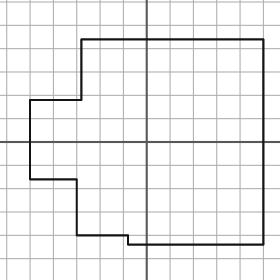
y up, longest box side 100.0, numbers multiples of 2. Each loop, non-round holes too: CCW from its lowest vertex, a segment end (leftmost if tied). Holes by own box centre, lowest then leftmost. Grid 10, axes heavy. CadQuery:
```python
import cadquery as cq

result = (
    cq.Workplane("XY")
    .moveTo(-8.0, -44.0)
    .lineTo(50.0, -44.0)
    .lineTo(50.0, 44.0)
    .lineTo(-28.0, 44.0)
    .lineTo(-28.0, 18.0)
    .lineTo(-50.0, 18.0)
    .lineTo(-50.0, -16.0)
    .lineTo(-30.0, -16.0)
    .lineTo(-30.0, -40.0)
    .lineTo(-8.0, -40.0)
    .close()
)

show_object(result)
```